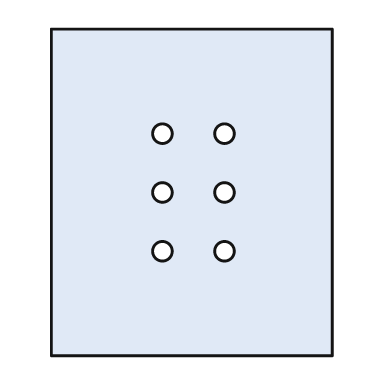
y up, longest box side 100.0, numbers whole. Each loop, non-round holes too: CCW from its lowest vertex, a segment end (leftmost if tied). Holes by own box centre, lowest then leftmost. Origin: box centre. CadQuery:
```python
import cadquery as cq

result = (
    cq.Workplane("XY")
    .moveTo(-43.0, -50.0)
    .lineTo(43.0, -50.0)
    .lineTo(43.0, 50.0)
    .lineTo(-43.0, 50.0)
    .close()
    .moveTo(-9.0, -18.0)
    .circle(3.0)
    .moveTo(10.0, -18.0)
    .circle(3.0)
    .moveTo(-9.0, 0.0)
    .circle(3.0)
    .moveTo(10.0, 0.0)
    .circle(3.0)
    .moveTo(-9.0, 18.0)
    .circle(3.0)
    .moveTo(10.0, 18.0)
    .circle(3.0)
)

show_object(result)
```